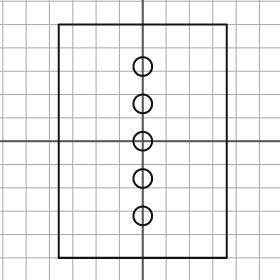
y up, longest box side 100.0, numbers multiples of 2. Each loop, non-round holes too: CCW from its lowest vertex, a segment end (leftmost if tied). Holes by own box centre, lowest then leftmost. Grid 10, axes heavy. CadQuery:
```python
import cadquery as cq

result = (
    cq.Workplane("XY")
    .moveTo(-36.0, -50.0)
    .lineTo(36.0, -50.0)
    .lineTo(36.0, 50.0)
    .lineTo(-36.0, 50.0)
    .close()
    .moveTo(0.0, -32.0)
    .circle(4.0)
    .moveTo(0.0, -16.0)
    .circle(4.0)
    .moveTo(0.0, 0.0)
    .circle(4.0)
    .moveTo(0.0, 16.0)
    .circle(4.0)
    .moveTo(0.0, 32.0)
    .circle(4.0)
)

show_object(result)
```